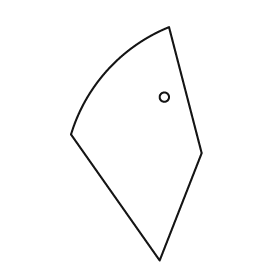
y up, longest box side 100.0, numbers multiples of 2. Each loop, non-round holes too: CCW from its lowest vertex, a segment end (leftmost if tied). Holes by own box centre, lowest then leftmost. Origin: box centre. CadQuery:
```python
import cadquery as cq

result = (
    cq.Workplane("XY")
    .moveTo(10.0, -50.0)
    .lineTo(28.0, -4.0)
    .lineTo(14.0, 50.0)
    .threePointArc((-12.0, 32.0), (-28.0, 4.0))
    .close()
    .moveTo(12.0, 20.0)
    .circle(2.0)
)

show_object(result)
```